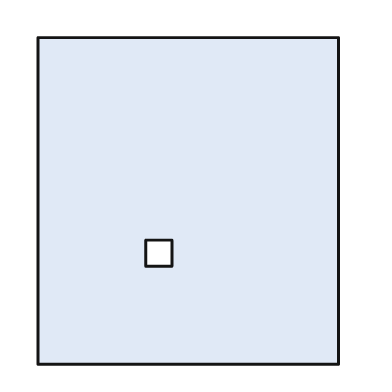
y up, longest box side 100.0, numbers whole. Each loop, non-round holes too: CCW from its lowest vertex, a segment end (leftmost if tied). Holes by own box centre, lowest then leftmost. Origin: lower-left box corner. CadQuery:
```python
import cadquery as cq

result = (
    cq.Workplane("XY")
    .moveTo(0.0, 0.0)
    .lineTo(92.0, 0.0)
    .lineTo(92.0, 100.0)
    .lineTo(0.0, 100.0)
    .close()
    .moveTo(33.0, 30.0)
    .lineTo(41.0, 30.0)
    .lineTo(41.0, 38.0)
    .lineTo(33.0, 38.0)
    .close()
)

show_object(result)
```